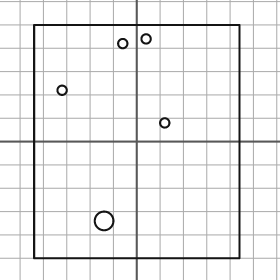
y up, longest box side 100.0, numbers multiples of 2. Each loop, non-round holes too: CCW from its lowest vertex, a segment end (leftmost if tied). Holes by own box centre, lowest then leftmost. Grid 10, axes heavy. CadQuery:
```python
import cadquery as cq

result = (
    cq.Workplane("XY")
    .moveTo(-44.0, -50.0)
    .lineTo(44.0, -50.0)
    .lineTo(44.0, 50.0)
    .lineTo(-44.0, 50.0)
    .close()
    .moveTo(-14.0, -34.0)
    .circle(4.0)
    .moveTo(12.0, 8.0)
    .circle(2.0)
    .moveTo(-32.0, 22.0)
    .circle(2.0)
    .moveTo(-6.0, 42.0)
    .circle(2.0)
    .moveTo(4.0, 44.0)
    .circle(2.0)
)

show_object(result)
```